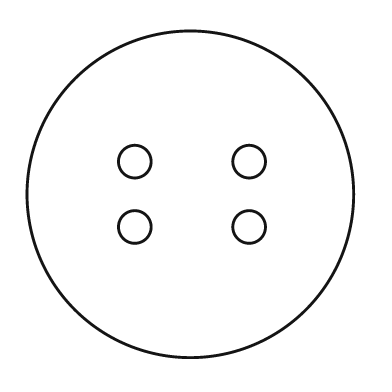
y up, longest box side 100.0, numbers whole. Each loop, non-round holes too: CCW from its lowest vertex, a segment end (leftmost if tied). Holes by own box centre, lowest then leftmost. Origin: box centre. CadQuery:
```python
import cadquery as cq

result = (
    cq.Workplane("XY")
    .moveTo(0.0, 0.0)
    .circle(50.0)
    .moveTo(-17.0, -10.0)
    .circle(5.0)
    .moveTo(18.0, -10.0)
    .circle(5.0)
    .moveTo(-17.0, 10.0)
    .circle(5.0)
    .moveTo(18.0, 10.0)
    .circle(5.0)
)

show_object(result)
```